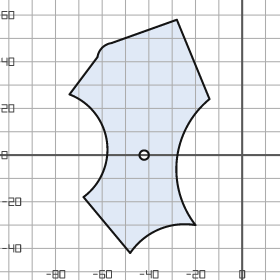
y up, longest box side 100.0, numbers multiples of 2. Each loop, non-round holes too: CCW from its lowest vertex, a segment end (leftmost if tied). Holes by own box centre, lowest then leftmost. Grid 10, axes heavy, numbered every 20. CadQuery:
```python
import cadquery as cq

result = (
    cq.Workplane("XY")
    .moveTo(-48.0, -42.0)
    .threePointArc((-36.0, -32.0), (-20.0, -30.0))
    .threePointArc((-28.0, -2.0), (-14.0, 24.0))
    .lineTo(-28.0, 58.0)
    .lineTo(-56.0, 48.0)
    .threePointArc((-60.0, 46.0), (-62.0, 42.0))
    .lineTo(-74.0, 26.0)
    .threePointArc((-58.0, 6.0), (-68.0, -18.0))
    .close()
    .moveTo(-42.0, 0.0)
    .circle(2.0)
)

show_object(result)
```